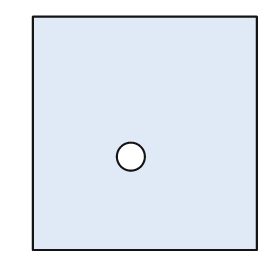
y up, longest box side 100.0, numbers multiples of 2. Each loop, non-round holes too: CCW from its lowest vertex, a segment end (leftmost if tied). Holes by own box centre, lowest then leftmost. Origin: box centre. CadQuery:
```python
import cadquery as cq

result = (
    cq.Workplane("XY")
    .moveTo(-48.0, -50.0)
    .lineTo(48.0, -50.0)
    .lineTo(48.0, 50.0)
    .lineTo(-48.0, 50.0)
    .close()
    .moveTo(-6.0, -10.0)
    .circle(6.0)
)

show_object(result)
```